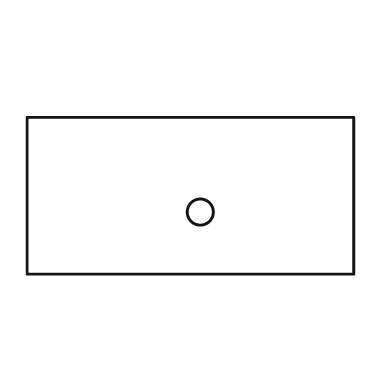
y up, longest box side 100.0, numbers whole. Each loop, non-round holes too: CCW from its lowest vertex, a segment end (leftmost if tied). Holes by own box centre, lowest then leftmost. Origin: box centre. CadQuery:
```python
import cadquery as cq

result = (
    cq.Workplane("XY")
    .moveTo(-50.0, -24.0)
    .lineTo(50.0, -24.0)
    .lineTo(50.0, 24.0)
    .lineTo(-50.0, 24.0)
    .close()
    .moveTo(3.0, -5.0)
    .circle(4.0)
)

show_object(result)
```